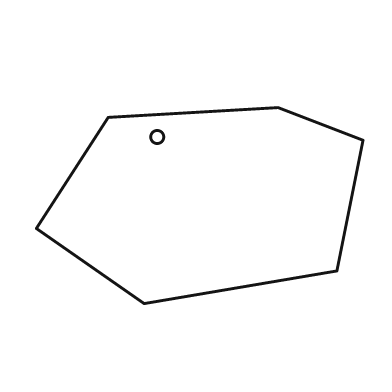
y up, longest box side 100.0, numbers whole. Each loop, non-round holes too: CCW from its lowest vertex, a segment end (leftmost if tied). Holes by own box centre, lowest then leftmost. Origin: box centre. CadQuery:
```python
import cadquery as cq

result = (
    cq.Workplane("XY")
    .moveTo(-17.0, -30.0)
    .lineTo(42.0, -20.0)
    .lineTo(50.0, 20.0)
    .lineTo(24.0, 30.0)
    .lineTo(-28.0, 27.0)
    .lineTo(-50.0, -7.0)
    .close()
    .moveTo(-13.0, 21.0)
    .circle(2.0)
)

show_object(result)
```